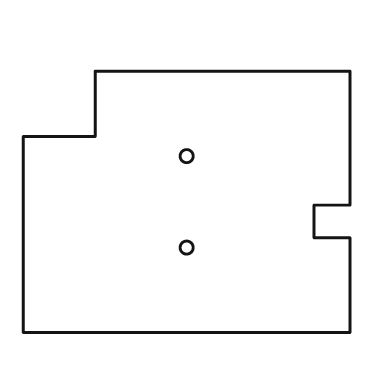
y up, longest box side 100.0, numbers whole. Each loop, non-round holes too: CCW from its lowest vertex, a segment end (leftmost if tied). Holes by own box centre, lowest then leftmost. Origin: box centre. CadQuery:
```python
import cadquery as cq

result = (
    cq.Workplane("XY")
    .moveTo(-50.0, -40.0)
    .lineTo(50.0, -40.0)
    .lineTo(50.0, -11.0)
    .lineTo(39.0, -11.0)
    .lineTo(39.0, -1.0)
    .lineTo(50.0, -1.0)
    .lineTo(50.0, 40.0)
    .lineTo(-28.0, 40.0)
    .lineTo(-28.0, 20.0)
    .lineTo(-50.0, 20.0)
    .close()
    .moveTo(0.0, -14.0)
    .circle(2.0)
    .moveTo(0.0, 14.0)
    .circle(2.0)
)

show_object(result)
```